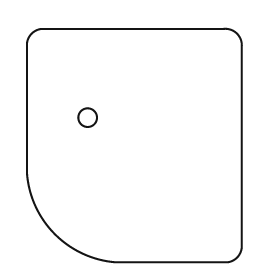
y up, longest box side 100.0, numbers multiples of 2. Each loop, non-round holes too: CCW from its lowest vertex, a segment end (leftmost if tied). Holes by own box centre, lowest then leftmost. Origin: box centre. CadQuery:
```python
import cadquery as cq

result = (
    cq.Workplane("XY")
    .moveTo(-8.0, -50.0)
    .lineTo(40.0, -50.0)
    .threePointArc((44.0, -48.0), (46.0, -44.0))
    .lineTo(46.0, 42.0)
    .threePointArc((44.0, 48.0), (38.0, 50.0))
    .lineTo(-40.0, 50.0)
    .threePointArc((-44.0, 48.0), (-46.0, 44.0))
    .lineTo(-46.0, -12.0)
    .threePointArc((-34.0, -38.0), (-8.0, -50.0))
    .close()
    .moveTo(-20.0, 12.0)
    .circle(4.0)
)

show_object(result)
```